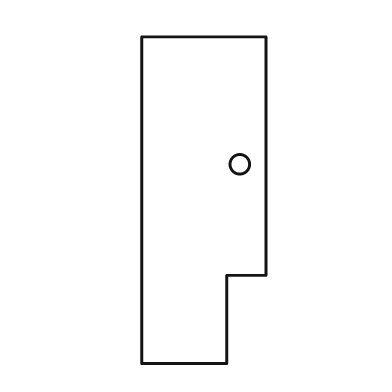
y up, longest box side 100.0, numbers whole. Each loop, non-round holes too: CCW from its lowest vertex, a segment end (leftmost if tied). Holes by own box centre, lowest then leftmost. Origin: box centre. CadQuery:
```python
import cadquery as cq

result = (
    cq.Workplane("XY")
    .moveTo(-19.0, -50.0)
    .lineTo(7.0, -50.0)
    .lineTo(7.0, -23.0)
    .lineTo(19.0, -23.0)
    .lineTo(19.0, 50.0)
    .lineTo(-19.0, 50.0)
    .close()
    .moveTo(11.0, 11.0)
    .circle(3.0)
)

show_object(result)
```